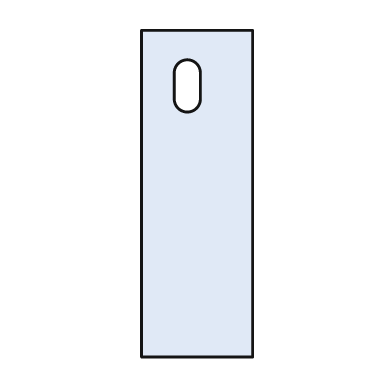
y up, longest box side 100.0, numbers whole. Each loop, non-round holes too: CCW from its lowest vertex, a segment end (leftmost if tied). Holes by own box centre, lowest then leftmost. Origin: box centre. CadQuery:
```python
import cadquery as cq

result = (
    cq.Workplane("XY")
    .moveTo(-17.0, -50.0)
    .lineTo(17.0, -50.0)
    .lineTo(17.0, 50.0)
    .lineTo(-17.0, 50.0)
    .close()
    .moveTo(-7.0, 29.0)
    .threePointArc((-3.0, 25.0), (1.0, 29.0))
    .lineTo(1.0, 37.0)
    .threePointArc((-3.0, 41.0), (-7.0, 37.0))
    .close()
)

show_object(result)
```